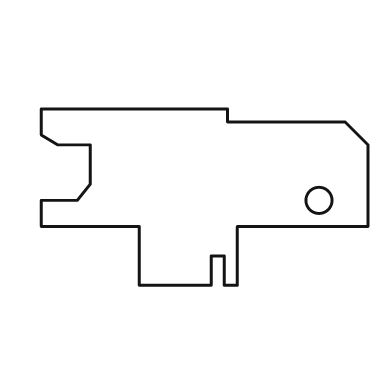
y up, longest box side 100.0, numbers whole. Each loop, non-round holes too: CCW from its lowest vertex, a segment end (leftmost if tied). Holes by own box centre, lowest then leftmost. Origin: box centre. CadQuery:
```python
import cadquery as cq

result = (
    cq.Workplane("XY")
    .moveTo(-20.0, -27.0)
    .lineTo(2.0, -27.0)
    .lineTo(2.0, -18.0)
    .lineTo(6.0, -18.0)
    .lineTo(6.0, -27.0)
    .lineTo(10.0, -27.0)
    .lineTo(10.0, -9.0)
    .lineTo(50.0, -9.0)
    .lineTo(50.0, 16.0)
    .lineTo(43.0, 23.0)
    .lineTo(7.0, 23.0)
    .lineTo(7.0, 27.0)
    .lineTo(-50.0, 27.0)
    .lineTo(-50.0, 19.0)
    .lineTo(-45.0, 16.0)
    .lineTo(-35.0, 16.0)
    .lineTo(-35.0, 4.0)
    .lineTo(-39.0, -1.0)
    .lineTo(-50.0, -1.0)
    .lineTo(-50.0, -9.0)
    .lineTo(-20.0, -9.0)
    .close()
    .moveTo(35.0, -1.0)
    .circle(4.0)
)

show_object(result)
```